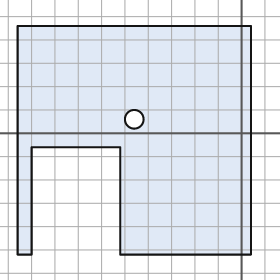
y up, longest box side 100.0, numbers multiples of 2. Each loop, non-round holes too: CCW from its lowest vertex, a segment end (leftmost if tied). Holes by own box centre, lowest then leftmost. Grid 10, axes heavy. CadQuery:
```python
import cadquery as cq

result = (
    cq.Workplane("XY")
    .moveTo(-96.0, -52.0)
    .lineTo(-90.0, -52.0)
    .lineTo(-90.0, -6.0)
    .lineTo(-52.0, -6.0)
    .lineTo(-52.0, -52.0)
    .lineTo(4.0, -52.0)
    .lineTo(4.0, 46.0)
    .lineTo(-96.0, 46.0)
    .close()
    .moveTo(-46.0, 6.0)
    .circle(4.0)
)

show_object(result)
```